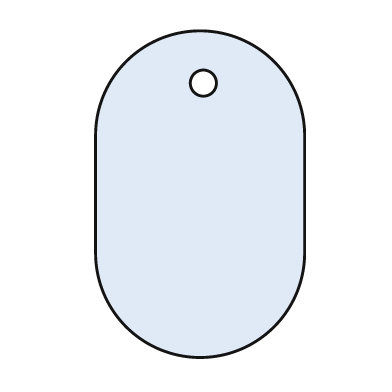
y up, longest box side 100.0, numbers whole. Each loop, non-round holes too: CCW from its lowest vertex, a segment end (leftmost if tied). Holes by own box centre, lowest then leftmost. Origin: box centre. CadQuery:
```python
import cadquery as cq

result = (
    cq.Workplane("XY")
    .moveTo(-32.0, -18.0)
    .threePointArc((0.0, -50.0), (32.0, -18.0))
    .lineTo(32.0, 18.0)
    .threePointArc((0.0, 50.0), (-32.0, 18.0))
    .close()
    .moveTo(1.0, 34.0)
    .circle(4.0)
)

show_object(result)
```